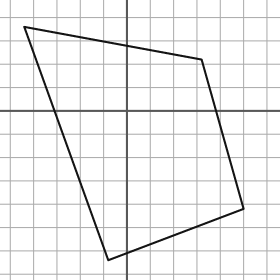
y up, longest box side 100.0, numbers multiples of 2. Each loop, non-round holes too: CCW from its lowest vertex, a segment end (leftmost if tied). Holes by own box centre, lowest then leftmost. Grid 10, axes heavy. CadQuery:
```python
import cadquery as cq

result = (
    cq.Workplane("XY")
    .moveTo(-8.0, -64.0)
    .lineTo(50.0, -42.0)
    .lineTo(32.0, 22.0)
    .lineTo(-44.0, 36.0)
    .close()
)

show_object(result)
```